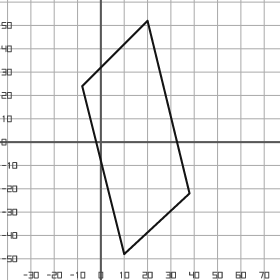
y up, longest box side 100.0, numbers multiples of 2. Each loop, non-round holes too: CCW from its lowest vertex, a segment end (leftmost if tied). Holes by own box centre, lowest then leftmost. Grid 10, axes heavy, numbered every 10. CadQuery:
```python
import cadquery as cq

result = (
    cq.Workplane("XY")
    .moveTo(10.0, -48.0)
    .lineTo(38.0, -22.0)
    .lineTo(20.0, 52.0)
    .lineTo(-8.0, 24.0)
    .close()
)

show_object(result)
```